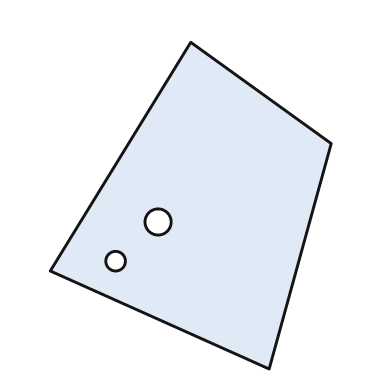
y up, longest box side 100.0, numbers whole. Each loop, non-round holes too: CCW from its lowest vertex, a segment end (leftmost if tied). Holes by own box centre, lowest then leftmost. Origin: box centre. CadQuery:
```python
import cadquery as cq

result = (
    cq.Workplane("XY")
    .moveTo(24.0, -50.0)
    .lineTo(43.0, 19.0)
    .lineTo(0.0, 50.0)
    .lineTo(-43.0, -20.0)
    .close()
    .moveTo(-23.0, -17.0)
    .circle(3.0)
    .moveTo(-10.0, -5.0)
    .circle(4.0)
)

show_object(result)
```